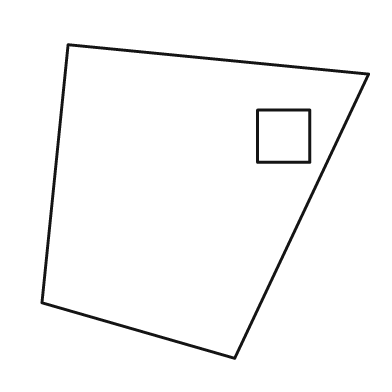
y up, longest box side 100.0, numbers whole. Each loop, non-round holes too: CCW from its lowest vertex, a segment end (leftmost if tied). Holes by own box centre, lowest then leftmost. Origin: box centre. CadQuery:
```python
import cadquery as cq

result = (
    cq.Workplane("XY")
    .moveTo(9.0, -48.0)
    .lineTo(50.0, 39.0)
    .lineTo(-42.0, 48.0)
    .lineTo(-50.0, -31.0)
    .close()
    .moveTo(16.0, 12.0)
    .lineTo(32.0, 12.0)
    .lineTo(32.0, 28.0)
    .lineTo(16.0, 28.0)
    .close()
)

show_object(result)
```